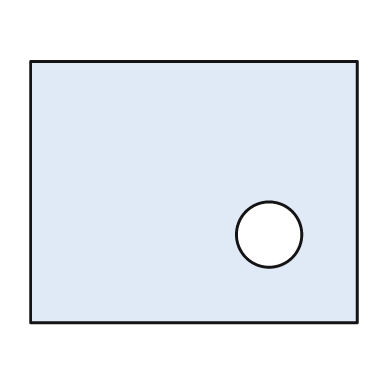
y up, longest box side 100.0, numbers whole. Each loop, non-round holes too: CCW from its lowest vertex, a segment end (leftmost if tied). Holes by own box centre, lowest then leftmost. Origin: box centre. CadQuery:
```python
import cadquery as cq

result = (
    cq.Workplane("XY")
    .moveTo(-50.0, -40.0)
    .lineTo(50.0, -40.0)
    .lineTo(50.0, 40.0)
    .lineTo(-50.0, 40.0)
    .close()
    .moveTo(23.0, -13.0)
    .circle(10.0)
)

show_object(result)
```